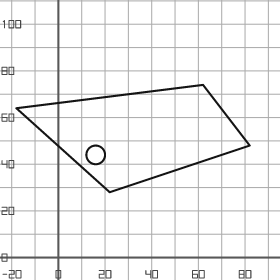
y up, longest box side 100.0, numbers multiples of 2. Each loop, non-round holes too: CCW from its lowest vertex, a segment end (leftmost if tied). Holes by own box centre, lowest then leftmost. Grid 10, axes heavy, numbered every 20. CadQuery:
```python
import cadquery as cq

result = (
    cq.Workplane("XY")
    .moveTo(22.0, 28.0)
    .lineTo(82.0, 48.0)
    .lineTo(62.0, 74.0)
    .lineTo(-18.0, 64.0)
    .close()
    .moveTo(16.0, 44.0)
    .circle(4.0)
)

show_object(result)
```